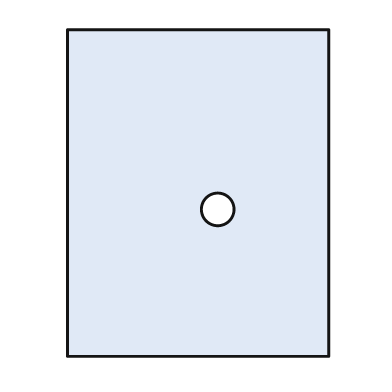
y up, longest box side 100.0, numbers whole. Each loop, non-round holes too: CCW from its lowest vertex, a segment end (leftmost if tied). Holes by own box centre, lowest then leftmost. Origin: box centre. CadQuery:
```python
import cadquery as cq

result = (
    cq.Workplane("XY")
    .moveTo(-40.0, -50.0)
    .lineTo(40.0, -50.0)
    .lineTo(40.0, 50.0)
    .lineTo(-40.0, 50.0)
    .close()
    .moveTo(6.0, -5.0)
    .circle(5.0)
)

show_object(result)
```